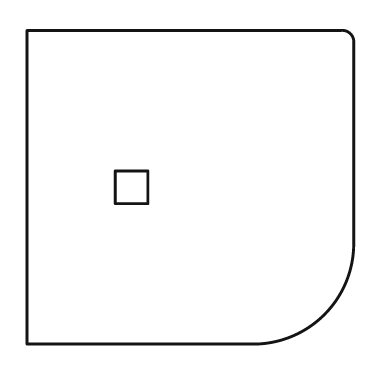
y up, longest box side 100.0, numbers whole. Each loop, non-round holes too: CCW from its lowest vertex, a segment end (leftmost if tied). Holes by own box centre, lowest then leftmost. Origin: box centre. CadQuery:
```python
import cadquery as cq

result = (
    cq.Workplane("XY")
    .moveTo(-50.0, -48.0)
    .lineTo(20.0, -48.0)
    .threePointArc((41.0, -39.0), (50.0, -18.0))
    .lineTo(50.0, 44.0)
    .threePointArc((49.0, 47.0), (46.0, 48.0))
    .lineTo(-50.0, 48.0)
    .close()
    .moveTo(-23.0, -5.0)
    .lineTo(-13.0, -5.0)
    .lineTo(-13.0, 5.0)
    .lineTo(-23.0, 5.0)
    .close()
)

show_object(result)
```